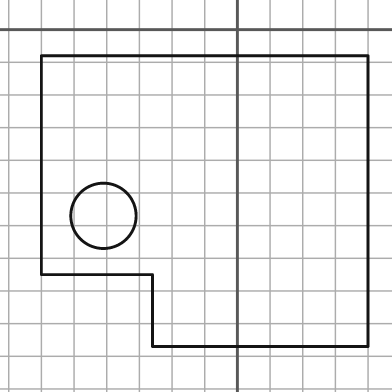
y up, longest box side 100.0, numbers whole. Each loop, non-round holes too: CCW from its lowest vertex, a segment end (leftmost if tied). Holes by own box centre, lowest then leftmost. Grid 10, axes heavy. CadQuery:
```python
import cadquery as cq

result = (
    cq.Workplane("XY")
    .moveTo(-26.0, -97.0)
    .lineTo(40.0, -97.0)
    .lineTo(40.0, -8.0)
    .lineTo(-60.0, -8.0)
    .lineTo(-60.0, -75.0)
    .lineTo(-26.0, -75.0)
    .close()
    .moveTo(-41.0, -57.0)
    .circle(10.0)
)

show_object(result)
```